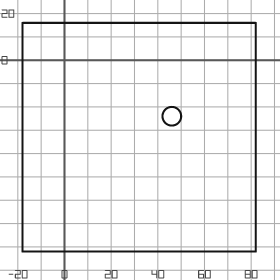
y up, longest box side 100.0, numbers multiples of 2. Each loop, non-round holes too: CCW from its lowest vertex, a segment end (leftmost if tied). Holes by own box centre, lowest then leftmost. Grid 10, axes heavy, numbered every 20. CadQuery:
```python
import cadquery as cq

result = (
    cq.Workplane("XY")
    .moveTo(-18.0, -82.0)
    .lineTo(82.0, -82.0)
    .lineTo(82.0, 16.0)
    .lineTo(-18.0, 16.0)
    .close()
    .moveTo(46.0, -24.0)
    .circle(4.0)
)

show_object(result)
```